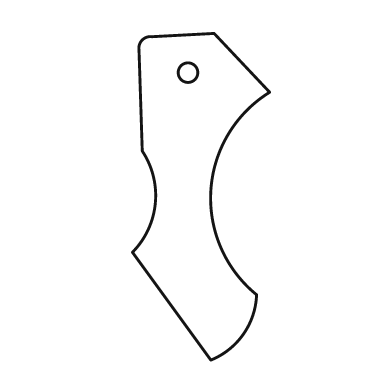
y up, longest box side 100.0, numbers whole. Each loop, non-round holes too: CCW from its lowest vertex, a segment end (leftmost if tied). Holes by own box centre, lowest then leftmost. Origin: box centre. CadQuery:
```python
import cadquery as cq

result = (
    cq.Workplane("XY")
    .moveTo(3.0, -50.0)
    .threePointArc((13.0, -42.0), (17.0, -30.0))
    .threePointArc((3.0, 2.0), (21.0, 32.0))
    .lineTo(4.0, 50.0)
    .lineTo(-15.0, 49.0)
    .threePointArc((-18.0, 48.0), (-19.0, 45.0))
    .lineTo(-18.0, 14.0)
    .threePointArc((-14.0, -2.0), (-21.0, -17.0))
    .close()
    .moveTo(-4.0, 38.0)
    .circle(3.0)
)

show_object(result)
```